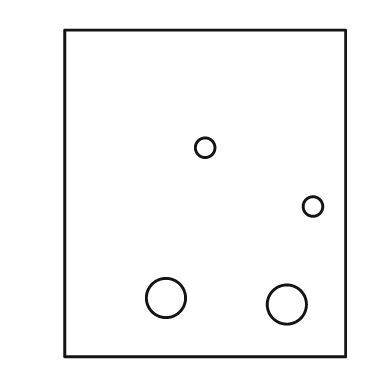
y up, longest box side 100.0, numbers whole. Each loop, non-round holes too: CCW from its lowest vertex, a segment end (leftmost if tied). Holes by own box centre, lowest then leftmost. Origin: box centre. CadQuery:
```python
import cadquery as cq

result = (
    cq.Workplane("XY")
    .moveTo(-43.0, -50.0)
    .lineTo(43.0, -50.0)
    .lineTo(43.0, 50.0)
    .lineTo(-43.0, 50.0)
    .close()
    .moveTo(25.0, -34.0)
    .circle(6.0)
    .moveTo(-12.0, -32.0)
    .circle(6.0)
    .moveTo(33.0, -4.0)
    .circle(3.0)
    .moveTo(0.0, 14.0)
    .circle(3.0)
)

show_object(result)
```